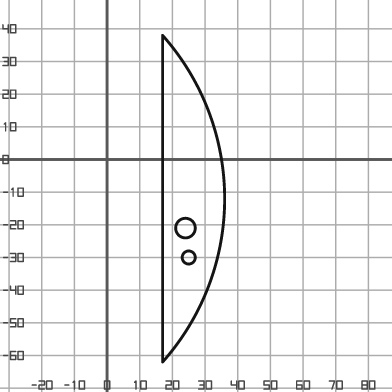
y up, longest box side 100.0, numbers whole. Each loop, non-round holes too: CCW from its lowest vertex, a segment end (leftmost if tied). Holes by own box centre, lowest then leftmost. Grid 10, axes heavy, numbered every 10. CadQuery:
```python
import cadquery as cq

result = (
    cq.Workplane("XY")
    .moveTo(17.0, -62.0)
    .threePointArc((36.0, -12.0), (17.0, 38.0))
    .close()
    .moveTo(25.0, -30.0)
    .circle(2.0)
    .moveTo(24.0, -21.0)
    .circle(3.0)
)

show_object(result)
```